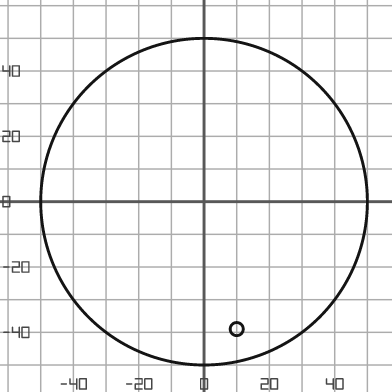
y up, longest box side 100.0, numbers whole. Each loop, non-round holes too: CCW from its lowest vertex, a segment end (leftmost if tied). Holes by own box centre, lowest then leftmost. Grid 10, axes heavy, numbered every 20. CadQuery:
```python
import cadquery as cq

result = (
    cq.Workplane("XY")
    .moveTo(0.0, 0.0)
    .circle(50.0)
    .moveTo(10.0, -39.0)
    .circle(2.0)
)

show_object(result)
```